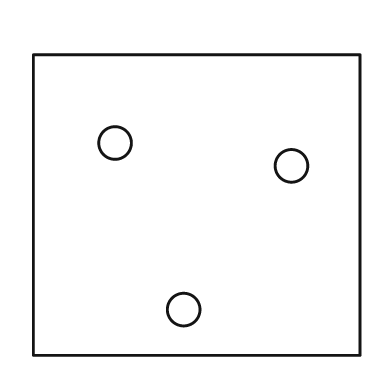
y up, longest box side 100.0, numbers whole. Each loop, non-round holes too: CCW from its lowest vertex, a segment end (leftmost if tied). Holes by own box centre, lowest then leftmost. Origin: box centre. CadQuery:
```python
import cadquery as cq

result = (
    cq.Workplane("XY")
    .moveTo(-50.0, -46.0)
    .lineTo(50.0, -46.0)
    .lineTo(50.0, 46.0)
    .lineTo(-50.0, 46.0)
    .close()
    .moveTo(-4.0, -32.0)
    .circle(5.0)
    .moveTo(29.0, 12.0)
    .circle(5.0)
    .moveTo(-25.0, 19.0)
    .circle(5.0)
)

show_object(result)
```